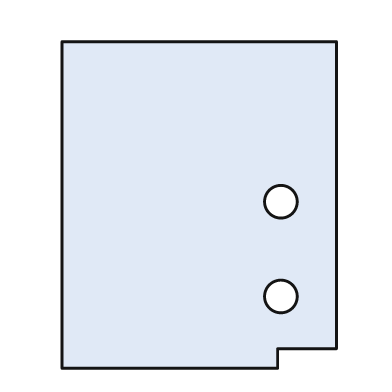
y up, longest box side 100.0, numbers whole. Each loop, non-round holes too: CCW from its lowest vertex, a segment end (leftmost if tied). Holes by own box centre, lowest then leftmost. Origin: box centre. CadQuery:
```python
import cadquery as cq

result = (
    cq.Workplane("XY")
    .moveTo(-42.0, -50.0)
    .lineTo(24.0, -50.0)
    .lineTo(24.0, -44.0)
    .lineTo(42.0, -44.0)
    .lineTo(42.0, 50.0)
    .lineTo(-42.0, 50.0)
    .close()
    .moveTo(25.0, -28.0)
    .circle(5.0)
    .moveTo(25.0, 1.0)
    .circle(5.0)
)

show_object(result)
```